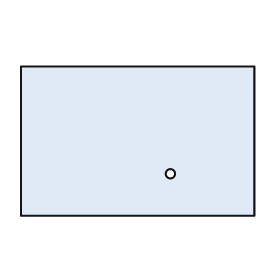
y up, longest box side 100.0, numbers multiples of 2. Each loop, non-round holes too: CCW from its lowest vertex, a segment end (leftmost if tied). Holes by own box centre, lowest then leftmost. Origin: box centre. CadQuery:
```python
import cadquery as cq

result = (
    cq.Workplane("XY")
    .moveTo(-50.0, -32.0)
    .lineTo(50.0, -32.0)
    .lineTo(50.0, 32.0)
    .lineTo(-50.0, 32.0)
    .close()
    .moveTo(14.0, -14.0)
    .circle(2.0)
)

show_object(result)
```